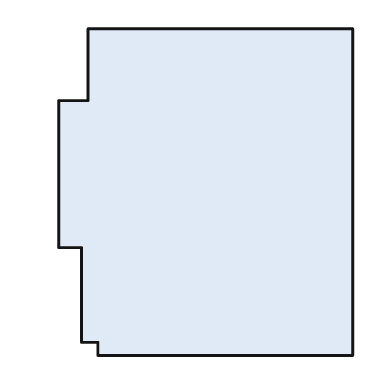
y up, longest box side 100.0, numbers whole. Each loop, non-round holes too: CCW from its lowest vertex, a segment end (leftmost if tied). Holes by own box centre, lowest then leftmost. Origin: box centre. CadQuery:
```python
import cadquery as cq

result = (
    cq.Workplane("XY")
    .moveTo(-33.0, -50.0)
    .lineTo(45.0, -50.0)
    .lineTo(45.0, 50.0)
    .lineTo(-36.0, 50.0)
    .lineTo(-36.0, 28.0)
    .lineTo(-45.0, 28.0)
    .lineTo(-45.0, -17.0)
    .lineTo(-38.0, -17.0)
    .lineTo(-38.0, -46.0)
    .lineTo(-33.0, -46.0)
    .close()
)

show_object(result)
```